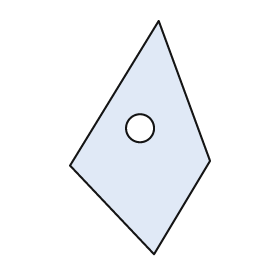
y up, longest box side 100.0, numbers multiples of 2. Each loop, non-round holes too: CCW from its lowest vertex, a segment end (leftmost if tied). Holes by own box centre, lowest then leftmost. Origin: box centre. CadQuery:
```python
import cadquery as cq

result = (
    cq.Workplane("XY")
    .moveTo(6.0, -50.0)
    .lineTo(30.0, -10.0)
    .lineTo(8.0, 50.0)
    .lineTo(-30.0, -12.0)
    .close()
    .moveTo(0.0, 4.0)
    .circle(6.0)
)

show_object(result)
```